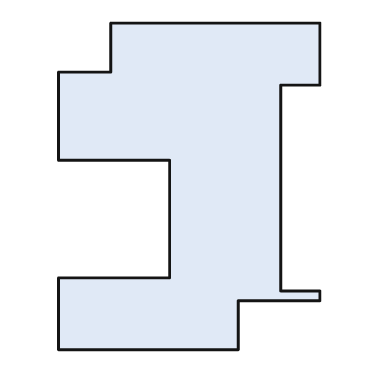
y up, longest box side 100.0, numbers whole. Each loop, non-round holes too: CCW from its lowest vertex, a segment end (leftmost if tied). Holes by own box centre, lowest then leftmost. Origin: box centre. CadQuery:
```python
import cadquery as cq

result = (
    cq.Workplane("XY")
    .moveTo(-40.0, -50.0)
    .lineTo(15.0, -50.0)
    .lineTo(15.0, -35.0)
    .lineTo(40.0, -35.0)
    .lineTo(40.0, -32.0)
    .lineTo(28.0, -32.0)
    .lineTo(28.0, 31.0)
    .lineTo(40.0, 31.0)
    .lineTo(40.0, 50.0)
    .lineTo(-24.0, 50.0)
    .lineTo(-24.0, 35.0)
    .lineTo(-40.0, 35.0)
    .lineTo(-40.0, 8.0)
    .lineTo(-6.0, 8.0)
    .lineTo(-6.0, -28.0)
    .lineTo(-40.0, -28.0)
    .close()
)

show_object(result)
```